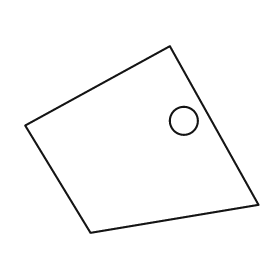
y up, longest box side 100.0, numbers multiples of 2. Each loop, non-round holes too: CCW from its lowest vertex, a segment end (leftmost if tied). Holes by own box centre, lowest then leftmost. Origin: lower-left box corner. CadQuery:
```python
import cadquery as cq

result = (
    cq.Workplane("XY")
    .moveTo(28.0, 0.0)
    .lineTo(100.0, 12.0)
    .lineTo(62.0, 80.0)
    .lineTo(0.0, 46.0)
    .close()
    .moveTo(68.0, 48.0)
    .circle(6.0)
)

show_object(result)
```